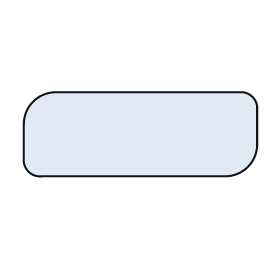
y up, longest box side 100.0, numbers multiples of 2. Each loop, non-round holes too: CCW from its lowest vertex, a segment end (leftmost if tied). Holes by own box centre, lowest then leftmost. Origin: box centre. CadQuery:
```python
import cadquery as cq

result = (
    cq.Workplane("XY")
    .moveTo(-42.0, -18.0)
    .lineTo(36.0, -18.0)
    .threePointArc((46.0, -14.0), (50.0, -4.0))
    .lineTo(50.0, 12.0)
    .threePointArc((48.0, 16.0), (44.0, 18.0))
    .lineTo(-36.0, 18.0)
    .threePointArc((-46.0, 14.0), (-50.0, 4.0))
    .lineTo(-50.0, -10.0)
    .threePointArc((-48.0, -16.0), (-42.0, -18.0))
    .close()
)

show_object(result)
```